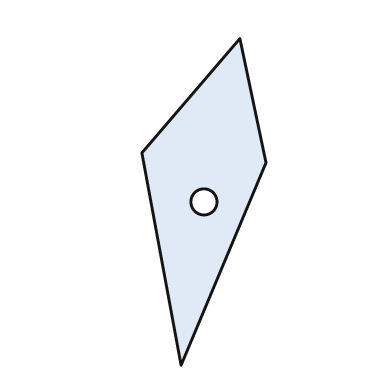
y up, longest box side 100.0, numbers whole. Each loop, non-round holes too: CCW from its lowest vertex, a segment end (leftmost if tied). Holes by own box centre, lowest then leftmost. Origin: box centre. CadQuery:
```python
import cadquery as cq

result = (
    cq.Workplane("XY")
    .moveTo(-7.0, -50.0)
    .lineTo(19.0, 12.0)
    .lineTo(11.0, 50.0)
    .lineTo(-19.0, 15.0)
    .close()
    .moveTo(0.0, 0.0)
    .circle(4.0)
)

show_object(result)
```